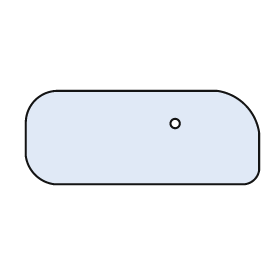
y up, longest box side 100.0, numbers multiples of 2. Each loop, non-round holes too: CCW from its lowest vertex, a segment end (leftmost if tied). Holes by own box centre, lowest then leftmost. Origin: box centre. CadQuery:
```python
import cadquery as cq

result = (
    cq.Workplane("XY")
    .moveTo(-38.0, -20.0)
    .lineTo(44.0, -20.0)
    .threePointArc((48.0, -18.0), (50.0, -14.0))
    .lineTo(50.0, 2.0)
    .threePointArc((44.0, 14.0), (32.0, 20.0))
    .lineTo(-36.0, 20.0)
    .threePointArc((-46.0, 16.0), (-50.0, 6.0))
    .lineTo(-50.0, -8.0)
    .threePointArc((-46.0, -16.0), (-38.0, -20.0))
    .close()
    .moveTo(14.0, 6.0)
    .circle(2.0)
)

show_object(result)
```